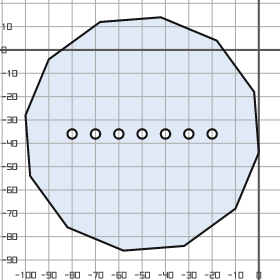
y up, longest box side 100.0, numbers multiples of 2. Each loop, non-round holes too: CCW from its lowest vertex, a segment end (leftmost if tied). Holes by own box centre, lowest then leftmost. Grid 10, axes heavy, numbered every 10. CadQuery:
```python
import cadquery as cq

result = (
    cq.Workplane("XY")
    .moveTo(-58.0, -86.0)
    .lineTo(-32.0, -84.0)
    .lineTo(-10.0, -68.0)
    .lineTo(0.0, -44.0)
    .lineTo(-2.0, -18.0)
    .lineTo(-18.0, 4.0)
    .lineTo(-42.0, 14.0)
    .lineTo(-68.0, 12.0)
    .lineTo(-90.0, -4.0)
    .lineTo(-100.0, -28.0)
    .lineTo(-98.0, -54.0)
    .lineTo(-82.0, -76.0)
    .close()
    .moveTo(-80.0, -36.0)
    .circle(2.0)
    .moveTo(-70.0, -36.0)
    .circle(2.0)
    .moveTo(-60.0, -36.0)
    .circle(2.0)
    .moveTo(-50.0, -36.0)
    .circle(2.0)
    .moveTo(-40.0, -36.0)
    .circle(2.0)
    .moveTo(-30.0, -36.0)
    .circle(2.0)
    .moveTo(-20.0, -36.0)
    .circle(2.0)
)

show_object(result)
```